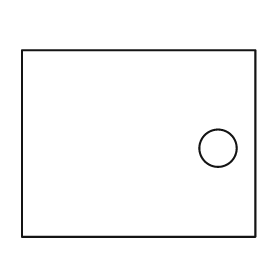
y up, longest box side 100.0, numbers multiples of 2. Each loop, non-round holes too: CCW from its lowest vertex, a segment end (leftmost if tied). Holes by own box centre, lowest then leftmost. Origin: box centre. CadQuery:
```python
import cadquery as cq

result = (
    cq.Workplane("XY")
    .moveTo(-50.0, -40.0)
    .lineTo(50.0, -40.0)
    .lineTo(50.0, 40.0)
    .lineTo(-50.0, 40.0)
    .close()
    .moveTo(34.0, -2.0)
    .circle(8.0)
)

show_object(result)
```